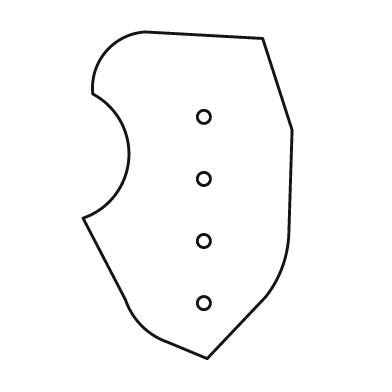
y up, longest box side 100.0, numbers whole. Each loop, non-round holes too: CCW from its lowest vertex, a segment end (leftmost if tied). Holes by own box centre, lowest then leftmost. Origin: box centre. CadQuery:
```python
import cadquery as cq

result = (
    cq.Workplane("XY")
    .moveTo(6.0, -50.0)
    .lineTo(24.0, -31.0)
    .threePointArc((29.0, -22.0), (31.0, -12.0))
    .lineTo(32.0, 20.0)
    .lineTo(23.0, 48.0)
    .lineTo(-13.0, 50.0)
    .threePointArc((-25.0, 44.0), (-29.0, 31.0))
    .threePointArc((-18.0, 11.0), (-32.0, -7.0))
    .lineTo(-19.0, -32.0)
    .threePointArc((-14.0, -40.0), (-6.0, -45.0))
    .close()
    .moveTo(5.0, -33.0)
    .circle(2.0)
    .moveTo(5.0, -14.0)
    .circle(2.0)
    .moveTo(5.0, 5.0)
    .circle(2.0)
    .moveTo(5.0, 24.0)
    .circle(2.0)
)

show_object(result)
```